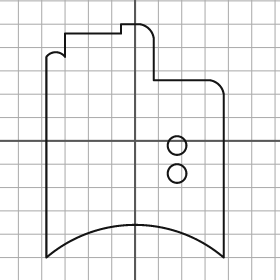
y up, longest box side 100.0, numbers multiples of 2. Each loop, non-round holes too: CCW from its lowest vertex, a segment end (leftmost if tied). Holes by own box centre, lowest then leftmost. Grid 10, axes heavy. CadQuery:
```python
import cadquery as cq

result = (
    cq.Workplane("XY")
    .moveTo(-38.0, -50.0)
    .threePointArc((0.0, -36.0), (38.0, -50.0))
    .lineTo(38.0, 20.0)
    .threePointArc((36.0, 24.0), (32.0, 26.0))
    .lineTo(8.0, 26.0)
    .lineTo(8.0, 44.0)
    .threePointArc((6.0, 48.0), (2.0, 50.0))
    .lineTo(-6.0, 50.0)
    .lineTo(-6.0, 46.0)
    .lineTo(-30.0, 46.0)
    .lineTo(-30.0, 36.0)
    .threePointArc((-34.0, 38.0), (-38.0, 36.0))
    .close()
    .moveTo(18.0, -14.0)
    .circle(4.0)
    .moveTo(18.0, -2.0)
    .circle(4.0)
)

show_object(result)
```